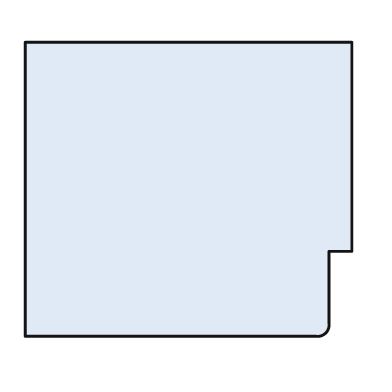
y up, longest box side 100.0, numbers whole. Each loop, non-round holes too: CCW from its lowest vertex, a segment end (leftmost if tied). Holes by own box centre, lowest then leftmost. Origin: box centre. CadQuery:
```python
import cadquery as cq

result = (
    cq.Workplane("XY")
    .moveTo(-50.0, -45.0)
    .lineTo(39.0, -45.0)
    .threePointArc((42.0, -44.0), (43.0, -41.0))
    .lineTo(43.0, -19.0)
    .lineTo(50.0, -19.0)
    .lineTo(50.0, 45.0)
    .lineTo(-50.0, 45.0)
    .close()
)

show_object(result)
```